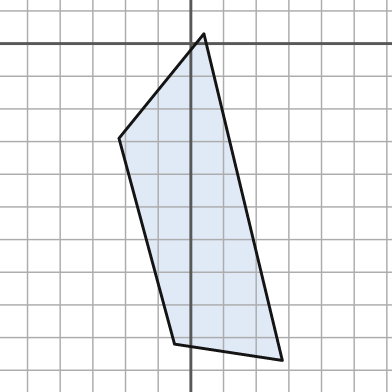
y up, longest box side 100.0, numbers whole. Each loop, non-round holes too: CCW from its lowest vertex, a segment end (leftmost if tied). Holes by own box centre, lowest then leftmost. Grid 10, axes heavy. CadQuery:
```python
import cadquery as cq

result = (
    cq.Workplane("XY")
    .moveTo(28.0, -97.0)
    .lineTo(4.0, 3.0)
    .lineTo(-22.0, -29.0)
    .lineTo(-5.0, -92.0)
    .close()
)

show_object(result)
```